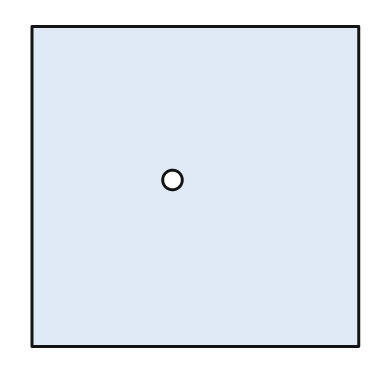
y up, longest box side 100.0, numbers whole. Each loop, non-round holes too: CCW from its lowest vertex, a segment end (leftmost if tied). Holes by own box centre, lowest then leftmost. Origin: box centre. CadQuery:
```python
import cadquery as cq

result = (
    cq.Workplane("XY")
    .moveTo(-50.0, -49.0)
    .lineTo(50.0, -49.0)
    .lineTo(50.0, 49.0)
    .lineTo(-50.0, 49.0)
    .close()
    .moveTo(-7.0, 2.0)
    .circle(3.0)
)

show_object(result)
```